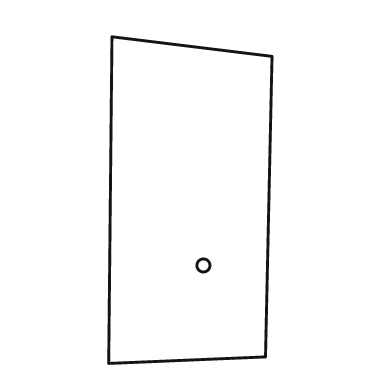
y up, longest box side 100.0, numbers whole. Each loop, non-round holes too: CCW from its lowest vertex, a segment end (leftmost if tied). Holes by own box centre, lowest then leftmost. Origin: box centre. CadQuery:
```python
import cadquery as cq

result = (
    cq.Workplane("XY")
    .moveTo(-25.0, -50.0)
    .lineTo(23.0, -48.0)
    .lineTo(25.0, 44.0)
    .lineTo(-24.0, 50.0)
    .close()
    .moveTo(4.0, -20.0)
    .circle(2.0)
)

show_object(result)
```